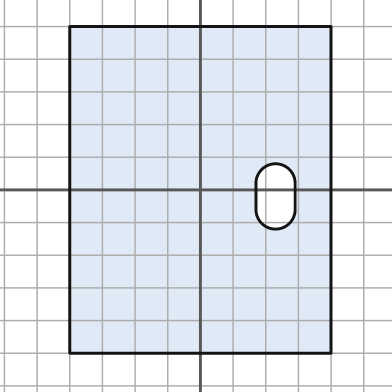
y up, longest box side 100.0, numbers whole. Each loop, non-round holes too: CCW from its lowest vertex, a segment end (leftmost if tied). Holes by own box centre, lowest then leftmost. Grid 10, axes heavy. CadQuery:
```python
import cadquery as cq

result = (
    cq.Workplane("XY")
    .moveTo(-40.0, -50.0)
    .lineTo(40.0, -50.0)
    .lineTo(40.0, 50.0)
    .lineTo(-40.0, 50.0)
    .close()
    .moveTo(17.0, -6.0)
    .threePointArc((23.0, -12.0), (29.0, -6.0))
    .lineTo(29.0, 2.0)
    .threePointArc((23.0, 8.0), (17.0, 2.0))
    .close()
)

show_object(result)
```